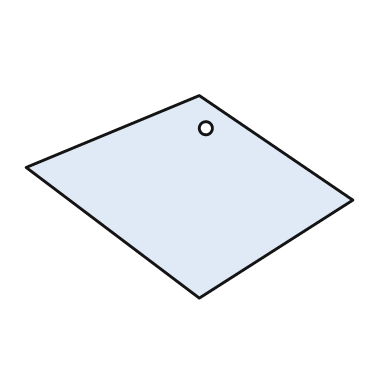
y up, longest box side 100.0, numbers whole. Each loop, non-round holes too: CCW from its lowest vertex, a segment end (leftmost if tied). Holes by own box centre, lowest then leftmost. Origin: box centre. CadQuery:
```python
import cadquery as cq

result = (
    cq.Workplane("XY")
    .moveTo(3.0, -31.0)
    .lineTo(50.0, -1.0)
    .lineTo(3.0, 31.0)
    .lineTo(-50.0, 9.0)
    .close()
    .moveTo(5.0, 21.0)
    .circle(2.0)
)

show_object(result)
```